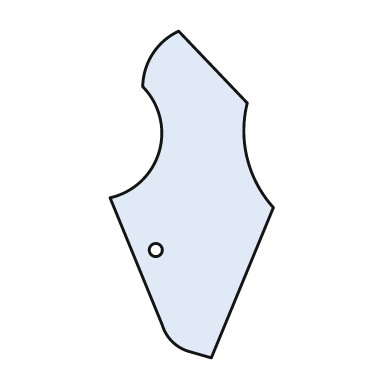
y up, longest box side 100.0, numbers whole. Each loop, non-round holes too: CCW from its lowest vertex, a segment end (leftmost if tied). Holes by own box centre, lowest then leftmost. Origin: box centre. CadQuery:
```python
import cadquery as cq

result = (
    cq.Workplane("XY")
    .moveTo(6.0, -50.0)
    .lineTo(25.0, -4.0)
    .threePointArc((17.0, 11.0), (17.0, 28.0))
    .lineTo(-4.0, 50.0)
    .threePointArc((-12.0, 43.0), (-15.0, 33.0))
    .threePointArc((-10.0, 13.0), (-25.0, -1.0))
    .lineTo(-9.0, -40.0)
    .threePointArc((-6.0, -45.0), (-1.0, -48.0))
    .close()
    .moveTo(-11.0, -17.0)
    .circle(2.0)
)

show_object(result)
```